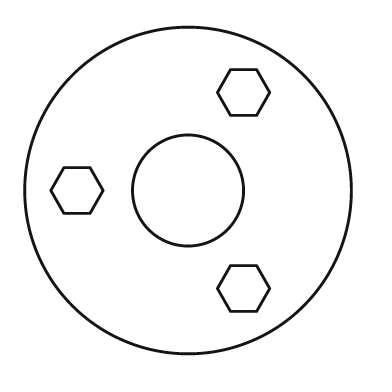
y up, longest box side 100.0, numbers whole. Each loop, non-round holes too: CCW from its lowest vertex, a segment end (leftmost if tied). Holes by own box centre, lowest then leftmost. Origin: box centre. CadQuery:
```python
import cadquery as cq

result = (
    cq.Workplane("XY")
    .moveTo(0.0, 0.0)
    .circle(50.0)
    .moveTo(13.0, -37.0)
    .lineTo(21.0, -37.0)
    .lineTo(25.0, -30.0)
    .lineTo(21.0, -23.0)
    .lineTo(13.0, -23.0)
    .lineTo(9.0, -30.0)
    .close()
    .moveTo(-38.0, -7.0)
    .lineTo(-30.0, -7.0)
    .lineTo(-26.0, 0.0)
    .lineTo(-30.0, 7.0)
    .lineTo(-38.0, 7.0)
    .lineTo(-42.0, 0.0)
    .close()
    .moveTo(0.0, 0.0)
    .circle(17.0)
    .moveTo(13.0, 23.0)
    .lineTo(21.0, 23.0)
    .lineTo(25.0, 30.0)
    .lineTo(21.0, 37.0)
    .lineTo(13.0, 37.0)
    .lineTo(9.0, 30.0)
    .close()
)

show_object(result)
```